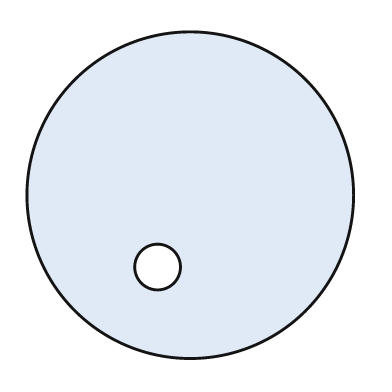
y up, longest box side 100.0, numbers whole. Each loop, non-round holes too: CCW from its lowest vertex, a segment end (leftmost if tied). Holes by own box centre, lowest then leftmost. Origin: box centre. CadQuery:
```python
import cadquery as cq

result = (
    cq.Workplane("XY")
    .moveTo(0.0, 0.0)
    .circle(50.0)
    .moveTo(-10.0, -22.0)
    .circle(7.0)
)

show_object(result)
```